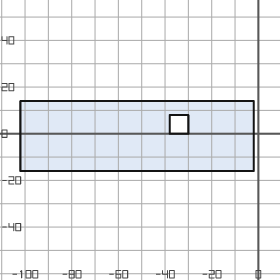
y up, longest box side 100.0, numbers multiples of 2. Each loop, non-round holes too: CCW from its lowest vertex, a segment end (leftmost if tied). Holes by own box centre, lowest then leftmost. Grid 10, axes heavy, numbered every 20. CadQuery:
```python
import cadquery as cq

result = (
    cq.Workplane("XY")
    .moveTo(-102.0, -16.0)
    .lineTo(-2.0, -16.0)
    .lineTo(-2.0, 14.0)
    .lineTo(-102.0, 14.0)
    .close()
    .moveTo(-38.0, 0.0)
    .lineTo(-30.0, 0.0)
    .lineTo(-30.0, 8.0)
    .lineTo(-38.0, 8.0)
    .close()
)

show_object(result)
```